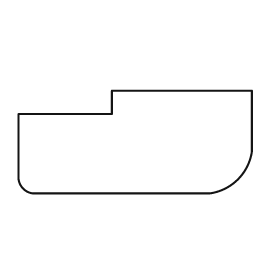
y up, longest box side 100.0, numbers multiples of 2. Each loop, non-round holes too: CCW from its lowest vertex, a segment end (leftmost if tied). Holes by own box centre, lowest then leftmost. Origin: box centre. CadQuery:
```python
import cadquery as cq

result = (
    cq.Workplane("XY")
    .moveTo(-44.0, -22.0)
    .lineTo(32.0, -22.0)
    .threePointArc((44.0, -16.0), (50.0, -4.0))
    .lineTo(50.0, 22.0)
    .lineTo(-10.0, 22.0)
    .lineTo(-10.0, 12.0)
    .lineTo(-50.0, 12.0)
    .lineTo(-50.0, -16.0)
    .threePointArc((-48.0, -20.0), (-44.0, -22.0))
    .close()
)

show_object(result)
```